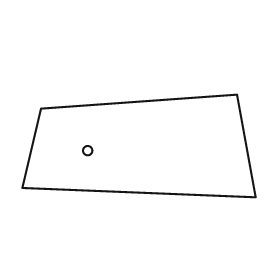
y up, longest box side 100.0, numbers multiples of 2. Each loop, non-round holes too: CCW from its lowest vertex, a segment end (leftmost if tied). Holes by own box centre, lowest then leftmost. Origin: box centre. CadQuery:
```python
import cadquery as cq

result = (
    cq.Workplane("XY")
    .moveTo(50.0, -22.0)
    .lineTo(42.0, 22.0)
    .lineTo(-42.0, 16.0)
    .lineTo(-50.0, -18.0)
    .close()
    .moveTo(-22.0, -2.0)
    .circle(2.0)
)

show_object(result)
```